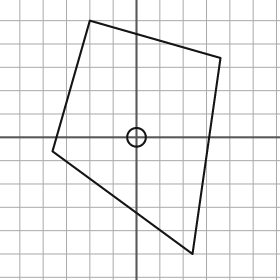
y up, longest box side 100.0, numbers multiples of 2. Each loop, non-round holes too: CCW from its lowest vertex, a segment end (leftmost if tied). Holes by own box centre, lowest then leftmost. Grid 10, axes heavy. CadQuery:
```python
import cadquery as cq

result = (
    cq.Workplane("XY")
    .moveTo(24.0, -50.0)
    .lineTo(36.0, 34.0)
    .lineTo(-20.0, 50.0)
    .lineTo(-36.0, -6.0)
    .close()
    .moveTo(0.0, 0.0)
    .circle(4.0)
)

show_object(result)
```